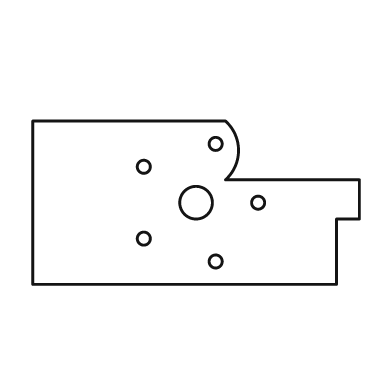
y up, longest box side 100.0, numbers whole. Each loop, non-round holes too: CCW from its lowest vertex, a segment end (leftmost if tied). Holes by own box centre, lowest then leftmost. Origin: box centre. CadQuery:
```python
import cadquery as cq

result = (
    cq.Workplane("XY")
    .moveTo(-50.0, -25.0)
    .lineTo(43.0, -25.0)
    .lineTo(43.0, -5.0)
    .lineTo(50.0, -5.0)
    .lineTo(50.0, 7.0)
    .lineTo(9.0, 7.0)
    .threePointArc((13.0, 16.0), (9.0, 25.0))
    .lineTo(-50.0, 25.0)
    .close()
    .moveTo(6.0, -18.0)
    .circle(2.0)
    .moveTo(-16.0, -11.0)
    .circle(2.0)
    .moveTo(0.0, 0.0)
    .circle(5.0)
    .moveTo(19.0, 0.0)
    .circle(2.0)
    .moveTo(-16.0, 11.0)
    .circle(2.0)
    .moveTo(6.0, 18.0)
    .circle(2.0)
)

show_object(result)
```